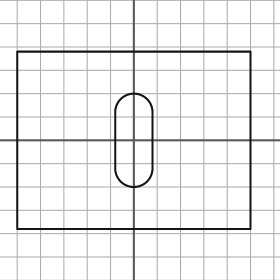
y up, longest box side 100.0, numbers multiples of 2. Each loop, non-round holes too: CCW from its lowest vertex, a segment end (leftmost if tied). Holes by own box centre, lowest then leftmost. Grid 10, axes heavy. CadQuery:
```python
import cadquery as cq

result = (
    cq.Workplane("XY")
    .moveTo(-50.0, -38.0)
    .lineTo(50.0, -38.0)
    .lineTo(50.0, 38.0)
    .lineTo(-50.0, 38.0)
    .close()
    .moveTo(-8.0, -12.0)
    .threePointArc((0.0, -20.0), (8.0, -12.0))
    .lineTo(8.0, 12.0)
    .threePointArc((0.0, 20.0), (-8.0, 12.0))
    .close()
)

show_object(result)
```